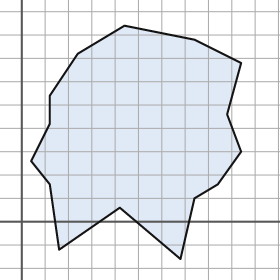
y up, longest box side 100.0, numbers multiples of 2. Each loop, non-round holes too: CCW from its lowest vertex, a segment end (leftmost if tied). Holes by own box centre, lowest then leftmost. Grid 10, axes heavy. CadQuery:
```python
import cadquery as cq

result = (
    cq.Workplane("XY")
    .moveTo(68.0, -16.0)
    .lineTo(74.0, 10.0)
    .lineTo(84.0, 16.0)
    .lineTo(94.0, 30.0)
    .lineTo(88.0, 46.0)
    .lineTo(94.0, 68.0)
    .lineTo(74.0, 78.0)
    .lineTo(44.0, 84.0)
    .lineTo(24.0, 72.0)
    .lineTo(12.0, 54.0)
    .lineTo(12.0, 42.0)
    .lineTo(4.0, 26.0)
    .lineTo(12.0, 16.0)
    .lineTo(16.0, -12.0)
    .lineTo(42.0, 6.0)
    .close()
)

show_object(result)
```